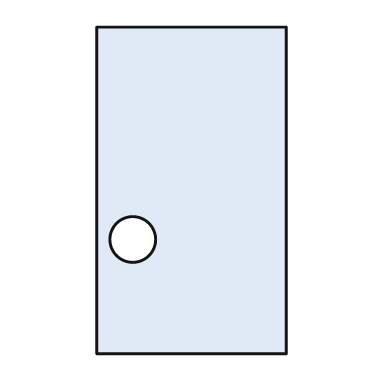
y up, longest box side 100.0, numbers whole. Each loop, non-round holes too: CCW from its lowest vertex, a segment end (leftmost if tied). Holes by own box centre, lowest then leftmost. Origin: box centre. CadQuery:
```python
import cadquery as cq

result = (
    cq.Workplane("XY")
    .moveTo(-29.0, -50.0)
    .lineTo(29.0, -50.0)
    .lineTo(29.0, 50.0)
    .lineTo(-29.0, 50.0)
    .close()
    .moveTo(-18.0, -15.0)
    .circle(7.0)
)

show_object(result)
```